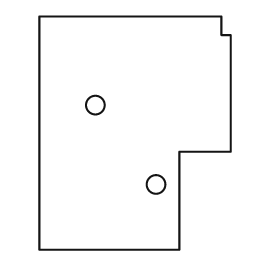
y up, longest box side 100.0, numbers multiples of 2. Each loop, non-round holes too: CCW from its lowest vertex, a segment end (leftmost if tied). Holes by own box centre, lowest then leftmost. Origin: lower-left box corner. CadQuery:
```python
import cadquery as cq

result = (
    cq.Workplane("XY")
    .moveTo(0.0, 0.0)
    .lineTo(60.0, 0.0)
    .lineTo(60.0, 42.0)
    .lineTo(82.0, 42.0)
    .lineTo(82.0, 92.0)
    .lineTo(78.0, 92.0)
    .lineTo(78.0, 100.0)
    .lineTo(0.0, 100.0)
    .close()
    .moveTo(50.0, 28.0)
    .circle(4.0)
    .moveTo(24.0, 62.0)
    .circle(4.0)
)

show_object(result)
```